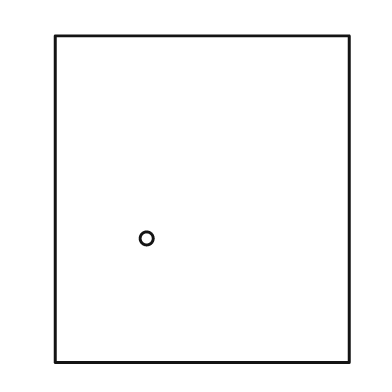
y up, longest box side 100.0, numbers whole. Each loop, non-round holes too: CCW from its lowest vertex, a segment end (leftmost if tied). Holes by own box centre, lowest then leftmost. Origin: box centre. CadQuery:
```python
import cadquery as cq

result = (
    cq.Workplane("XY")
    .moveTo(-45.0, -50.0)
    .lineTo(45.0, -50.0)
    .lineTo(45.0, 50.0)
    .lineTo(-45.0, 50.0)
    .close()
    .moveTo(-17.0, -12.0)
    .circle(2.0)
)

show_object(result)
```